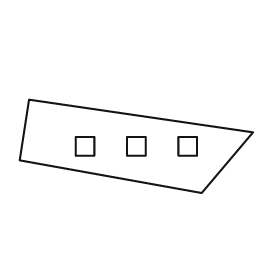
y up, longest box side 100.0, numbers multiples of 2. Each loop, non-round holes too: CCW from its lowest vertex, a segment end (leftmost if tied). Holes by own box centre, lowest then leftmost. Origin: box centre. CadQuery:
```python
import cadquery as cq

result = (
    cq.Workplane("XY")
    .moveTo(28.0, -20.0)
    .lineTo(50.0, 6.0)
    .lineTo(-46.0, 20.0)
    .lineTo(-50.0, -6.0)
    .close()
    .moveTo(-26.0, -4.0)
    .lineTo(-18.0, -4.0)
    .lineTo(-18.0, 4.0)
    .lineTo(-26.0, 4.0)
    .close()
    .moveTo(-4.0, -4.0)
    .lineTo(4.0, -4.0)
    .lineTo(4.0, 4.0)
    .lineTo(-4.0, 4.0)
    .close()
    .moveTo(18.0, -4.0)
    .lineTo(26.0, -4.0)
    .lineTo(26.0, 4.0)
    .lineTo(18.0, 4.0)
    .close()
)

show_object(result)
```